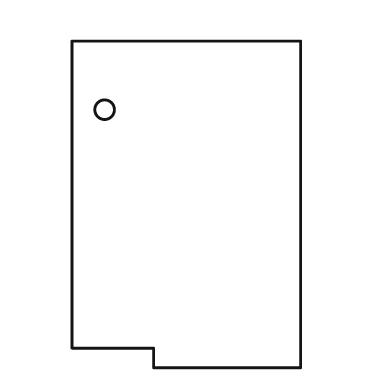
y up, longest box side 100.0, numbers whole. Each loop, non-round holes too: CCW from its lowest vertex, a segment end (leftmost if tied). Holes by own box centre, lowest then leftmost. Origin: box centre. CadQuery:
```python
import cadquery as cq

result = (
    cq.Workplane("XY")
    .moveTo(-10.0, -50.0)
    .lineTo(35.0, -50.0)
    .lineTo(35.0, 50.0)
    .lineTo(-35.0, 50.0)
    .lineTo(-35.0, -44.0)
    .lineTo(-10.0, -44.0)
    .close()
    .moveTo(-25.0, 29.0)
    .circle(3.0)
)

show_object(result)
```